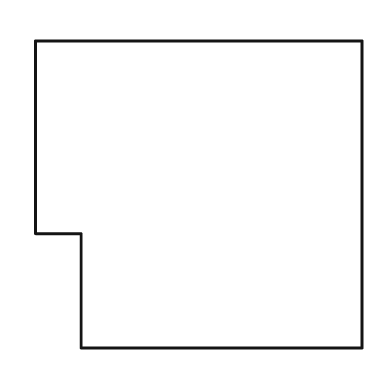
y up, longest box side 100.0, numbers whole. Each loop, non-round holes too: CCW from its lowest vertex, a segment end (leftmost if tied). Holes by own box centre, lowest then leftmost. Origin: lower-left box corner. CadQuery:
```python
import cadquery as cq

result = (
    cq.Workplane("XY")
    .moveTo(14.0, 0.0)
    .lineTo(100.0, 0.0)
    .lineTo(100.0, 94.0)
    .lineTo(0.0, 94.0)
    .lineTo(0.0, 35.0)
    .lineTo(14.0, 35.0)
    .close()
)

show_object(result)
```